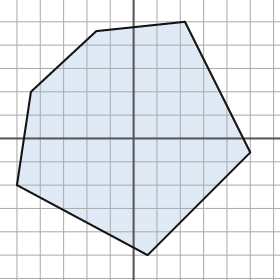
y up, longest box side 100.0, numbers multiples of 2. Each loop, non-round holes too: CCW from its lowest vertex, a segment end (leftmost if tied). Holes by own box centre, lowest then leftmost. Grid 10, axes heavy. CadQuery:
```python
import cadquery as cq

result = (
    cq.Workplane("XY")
    .moveTo(6.0, -50.0)
    .lineTo(50.0, -6.0)
    .lineTo(22.0, 50.0)
    .lineTo(-16.0, 46.0)
    .lineTo(-44.0, 20.0)
    .lineTo(-50.0, -20.0)
    .close()
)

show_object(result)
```